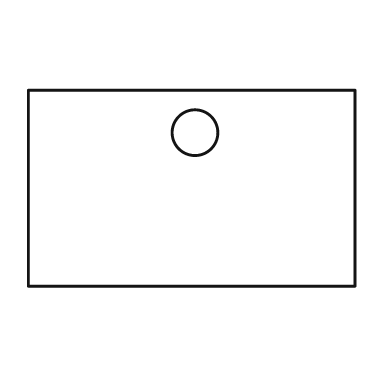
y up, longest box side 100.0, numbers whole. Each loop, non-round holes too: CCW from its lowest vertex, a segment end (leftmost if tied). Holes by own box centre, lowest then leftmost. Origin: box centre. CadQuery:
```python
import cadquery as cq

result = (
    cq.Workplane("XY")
    .moveTo(-50.0, -30.0)
    .lineTo(50.0, -30.0)
    .lineTo(50.0, 30.0)
    .lineTo(-50.0, 30.0)
    .close()
    .moveTo(1.0, 17.0)
    .circle(7.0)
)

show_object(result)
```